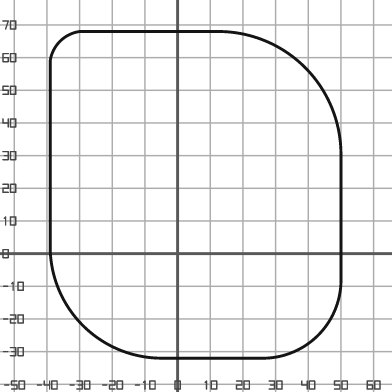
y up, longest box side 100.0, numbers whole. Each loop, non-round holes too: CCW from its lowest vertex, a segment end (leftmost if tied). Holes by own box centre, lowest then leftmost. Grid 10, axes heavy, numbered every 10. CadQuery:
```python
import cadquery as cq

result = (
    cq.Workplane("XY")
    .moveTo(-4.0, -32.0)
    .lineTo(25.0, -32.0)
    .threePointArc((43.0, -25.0), (50.0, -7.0))
    .lineTo(50.0, 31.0)
    .threePointArc((39.0, 57.0), (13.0, 68.0))
    .lineTo(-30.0, 68.0)
    .threePointArc((-36.0, 65.0), (-39.0, 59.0))
    .lineTo(-39.0, 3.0)
    .threePointArc((-29.0, -22.0), (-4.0, -32.0))
    .close()
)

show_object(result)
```